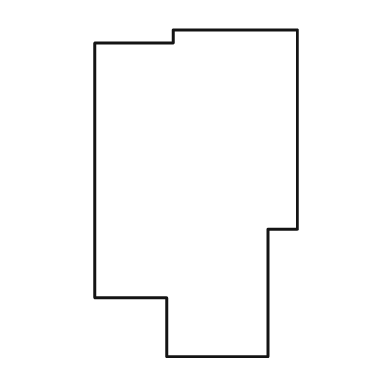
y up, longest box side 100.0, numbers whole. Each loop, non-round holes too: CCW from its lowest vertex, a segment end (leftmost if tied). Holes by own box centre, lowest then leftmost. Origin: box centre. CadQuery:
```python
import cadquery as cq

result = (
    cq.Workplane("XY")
    .moveTo(-9.0, -50.0)
    .lineTo(22.0, -50.0)
    .lineTo(22.0, -11.0)
    .lineTo(31.0, -11.0)
    .lineTo(31.0, 50.0)
    .lineTo(-7.0, 50.0)
    .lineTo(-7.0, 46.0)
    .lineTo(-31.0, 46.0)
    .lineTo(-31.0, -32.0)
    .lineTo(-9.0, -32.0)
    .close()
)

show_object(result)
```